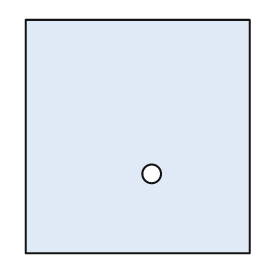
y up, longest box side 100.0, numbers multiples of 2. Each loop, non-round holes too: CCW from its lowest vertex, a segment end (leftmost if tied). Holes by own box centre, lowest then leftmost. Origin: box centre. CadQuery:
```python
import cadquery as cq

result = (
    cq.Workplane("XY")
    .moveTo(-48.0, -50.0)
    .lineTo(48.0, -50.0)
    .lineTo(48.0, 50.0)
    .lineTo(-48.0, 50.0)
    .close()
    .moveTo(6.0, -16.0)
    .circle(4.0)
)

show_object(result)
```